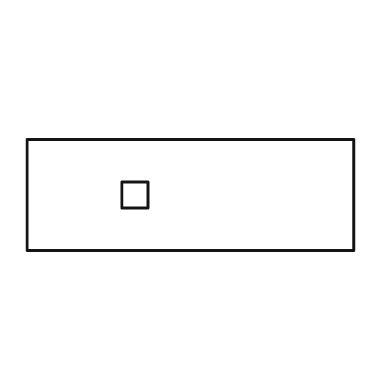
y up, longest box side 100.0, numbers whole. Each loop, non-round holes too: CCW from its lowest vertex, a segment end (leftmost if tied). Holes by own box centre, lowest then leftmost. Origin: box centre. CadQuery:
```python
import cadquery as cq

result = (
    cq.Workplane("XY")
    .moveTo(-50.0, -17.0)
    .lineTo(50.0, -17.0)
    .lineTo(50.0, 17.0)
    .lineTo(-50.0, 17.0)
    .close()
    .moveTo(-21.0, -4.0)
    .lineTo(-13.0, -4.0)
    .lineTo(-13.0, 4.0)
    .lineTo(-21.0, 4.0)
    .close()
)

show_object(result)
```